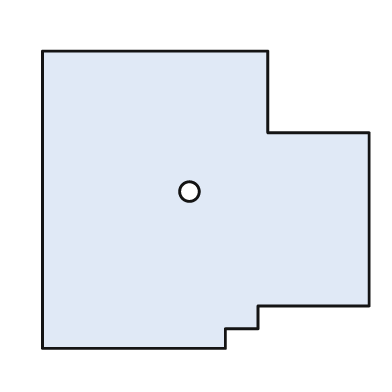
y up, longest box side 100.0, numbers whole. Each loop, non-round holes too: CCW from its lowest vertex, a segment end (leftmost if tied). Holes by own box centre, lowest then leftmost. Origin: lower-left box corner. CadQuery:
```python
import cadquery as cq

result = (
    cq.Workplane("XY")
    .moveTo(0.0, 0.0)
    .lineTo(56.0, 0.0)
    .lineTo(56.0, 6.0)
    .lineTo(66.0, 6.0)
    .lineTo(66.0, 13.0)
    .lineTo(100.0, 13.0)
    .lineTo(100.0, 66.0)
    .lineTo(69.0, 66.0)
    .lineTo(69.0, 91.0)
    .lineTo(0.0, 91.0)
    .close()
    .moveTo(45.0, 48.0)
    .circle(3.0)
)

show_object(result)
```